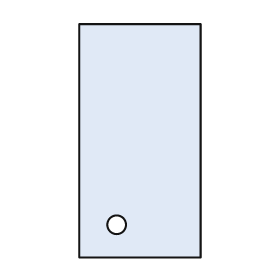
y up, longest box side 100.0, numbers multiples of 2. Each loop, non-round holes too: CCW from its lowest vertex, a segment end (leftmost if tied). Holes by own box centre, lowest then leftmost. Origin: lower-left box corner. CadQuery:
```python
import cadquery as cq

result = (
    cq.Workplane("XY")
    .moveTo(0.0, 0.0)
    .lineTo(52.0, 0.0)
    .lineTo(52.0, 100.0)
    .lineTo(0.0, 100.0)
    .close()
    .moveTo(16.0, 14.0)
    .circle(4.0)
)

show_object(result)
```